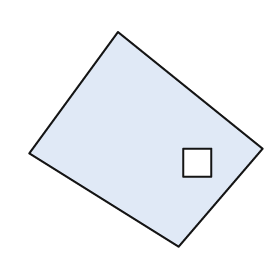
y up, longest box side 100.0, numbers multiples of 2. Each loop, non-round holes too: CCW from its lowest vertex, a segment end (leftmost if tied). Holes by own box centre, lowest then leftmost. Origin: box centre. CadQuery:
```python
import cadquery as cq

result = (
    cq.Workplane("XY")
    .moveTo(14.0, -46.0)
    .lineTo(50.0, -4.0)
    .lineTo(-12.0, 46.0)
    .lineTo(-50.0, -6.0)
    .close()
    .moveTo(16.0, -16.0)
    .lineTo(28.0, -16.0)
    .lineTo(28.0, -4.0)
    .lineTo(16.0, -4.0)
    .close()
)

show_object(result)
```